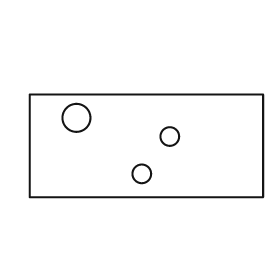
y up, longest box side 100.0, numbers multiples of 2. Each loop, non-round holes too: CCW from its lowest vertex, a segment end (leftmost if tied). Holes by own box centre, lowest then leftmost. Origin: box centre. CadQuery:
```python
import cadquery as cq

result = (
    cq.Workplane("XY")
    .moveTo(-50.0, -22.0)
    .lineTo(50.0, -22.0)
    .lineTo(50.0, 22.0)
    .lineTo(-50.0, 22.0)
    .close()
    .moveTo(-2.0, -12.0)
    .circle(4.0)
    .moveTo(10.0, 4.0)
    .circle(4.0)
    .moveTo(-30.0, 12.0)
    .circle(6.0)
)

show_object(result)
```